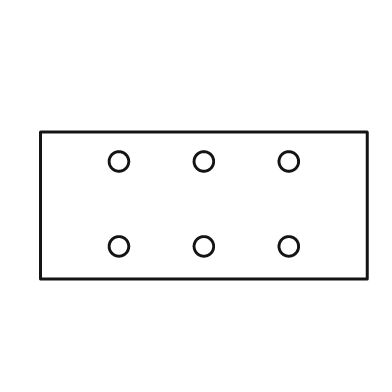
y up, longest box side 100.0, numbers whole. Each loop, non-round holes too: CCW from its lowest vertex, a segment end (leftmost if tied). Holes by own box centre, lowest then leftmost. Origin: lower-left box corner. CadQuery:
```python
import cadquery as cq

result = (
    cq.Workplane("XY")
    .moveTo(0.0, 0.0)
    .lineTo(100.0, 0.0)
    .lineTo(100.0, 45.0)
    .lineTo(0.0, 45.0)
    .close()
    .moveTo(24.0, 10.0)
    .circle(3.0)
    .moveTo(50.0, 10.0)
    .circle(3.0)
    .moveTo(76.0, 10.0)
    .circle(3.0)
    .moveTo(24.0, 36.0)
    .circle(3.0)
    .moveTo(50.0, 36.0)
    .circle(3.0)
    .moveTo(76.0, 36.0)
    .circle(3.0)
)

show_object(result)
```